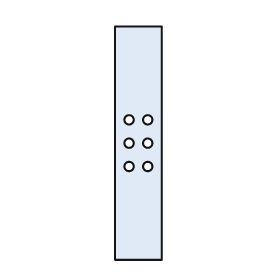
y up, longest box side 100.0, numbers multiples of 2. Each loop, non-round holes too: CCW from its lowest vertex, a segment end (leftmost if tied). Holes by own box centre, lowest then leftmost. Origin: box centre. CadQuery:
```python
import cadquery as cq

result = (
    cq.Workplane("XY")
    .moveTo(-10.0, -50.0)
    .lineTo(10.0, -50.0)
    .lineTo(10.0, 50.0)
    .lineTo(-10.0, 50.0)
    .close()
    .moveTo(-4.0, -10.0)
    .circle(2.0)
    .moveTo(4.0, -10.0)
    .circle(2.0)
    .moveTo(-4.0, 0.0)
    .circle(2.0)
    .moveTo(4.0, 0.0)
    .circle(2.0)
    .moveTo(-4.0, 10.0)
    .circle(2.0)
    .moveTo(4.0, 10.0)
    .circle(2.0)
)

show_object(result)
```